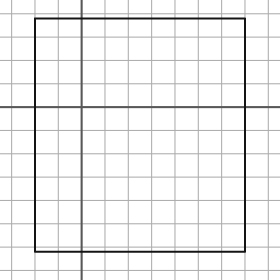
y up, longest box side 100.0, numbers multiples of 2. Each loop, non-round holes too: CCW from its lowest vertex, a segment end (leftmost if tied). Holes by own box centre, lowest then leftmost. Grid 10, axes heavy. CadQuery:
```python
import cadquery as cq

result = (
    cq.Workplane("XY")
    .moveTo(-20.0, -62.0)
    .lineTo(70.0, -62.0)
    .lineTo(70.0, 38.0)
    .lineTo(-20.0, 38.0)
    .close()
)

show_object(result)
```